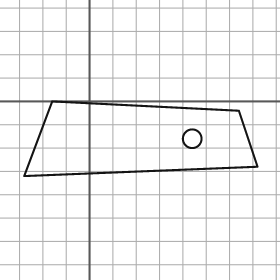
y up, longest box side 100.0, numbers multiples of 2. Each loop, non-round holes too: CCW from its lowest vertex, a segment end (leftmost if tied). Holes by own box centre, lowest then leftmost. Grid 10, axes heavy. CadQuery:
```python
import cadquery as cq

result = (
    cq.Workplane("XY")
    .moveTo(-28.0, -32.0)
    .lineTo(72.0, -28.0)
    .lineTo(64.0, -4.0)
    .lineTo(-16.0, 0.0)
    .close()
    .moveTo(44.0, -16.0)
    .circle(4.0)
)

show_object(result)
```